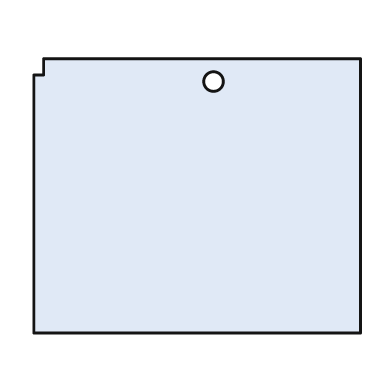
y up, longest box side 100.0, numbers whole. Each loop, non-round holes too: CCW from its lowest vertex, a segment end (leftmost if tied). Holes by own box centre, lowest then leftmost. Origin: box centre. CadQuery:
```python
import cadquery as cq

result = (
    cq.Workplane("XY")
    .moveTo(-50.0, -42.0)
    .lineTo(50.0, -42.0)
    .lineTo(50.0, 42.0)
    .lineTo(-47.0, 42.0)
    .lineTo(-47.0, 37.0)
    .lineTo(-50.0, 37.0)
    .close()
    .moveTo(5.0, 35.0)
    .circle(3.0)
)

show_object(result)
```